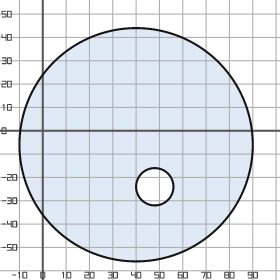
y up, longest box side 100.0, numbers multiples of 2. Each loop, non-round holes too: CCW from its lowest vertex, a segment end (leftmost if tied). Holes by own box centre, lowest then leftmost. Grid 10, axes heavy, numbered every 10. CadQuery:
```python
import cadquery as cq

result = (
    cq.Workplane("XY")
    .moveTo(40.0, -6.0)
    .circle(50.0)
    .moveTo(48.0, -24.0)
    .circle(8.0)
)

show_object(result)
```